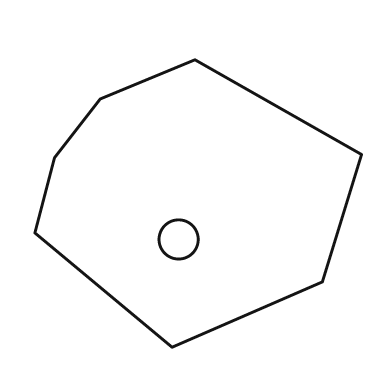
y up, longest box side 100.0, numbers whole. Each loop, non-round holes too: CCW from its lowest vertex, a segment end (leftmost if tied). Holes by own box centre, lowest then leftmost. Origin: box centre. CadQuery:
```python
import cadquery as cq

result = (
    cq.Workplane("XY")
    .moveTo(-8.0, -44.0)
    .lineTo(38.0, -24.0)
    .lineTo(50.0, 15.0)
    .lineTo(-1.0, 44.0)
    .lineTo(-30.0, 32.0)
    .lineTo(-44.0, 14.0)
    .lineTo(-50.0, -9.0)
    .close()
    .moveTo(-6.0, -11.0)
    .circle(6.0)
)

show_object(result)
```